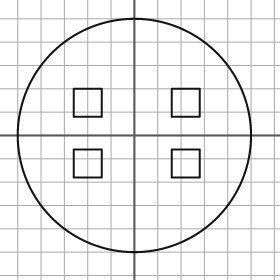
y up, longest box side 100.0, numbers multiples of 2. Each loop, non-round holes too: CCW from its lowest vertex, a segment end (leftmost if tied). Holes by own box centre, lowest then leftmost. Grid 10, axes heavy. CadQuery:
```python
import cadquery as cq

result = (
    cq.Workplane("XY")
    .moveTo(0.0, 0.0)
    .circle(50.0)
    .moveTo(-26.0, -18.0)
    .lineTo(-14.0, -18.0)
    .lineTo(-14.0, -6.0)
    .lineTo(-26.0, -6.0)
    .close()
    .moveTo(16.0, -18.0)
    .lineTo(28.0, -18.0)
    .lineTo(28.0, -6.0)
    .lineTo(16.0, -6.0)
    .close()
    .moveTo(-26.0, 8.0)
    .lineTo(-14.0, 8.0)
    .lineTo(-14.0, 20.0)
    .lineTo(-26.0, 20.0)
    .close()
    .moveTo(16.0, 8.0)
    .lineTo(28.0, 8.0)
    .lineTo(28.0, 20.0)
    .lineTo(16.0, 20.0)
    .close()
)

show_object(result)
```